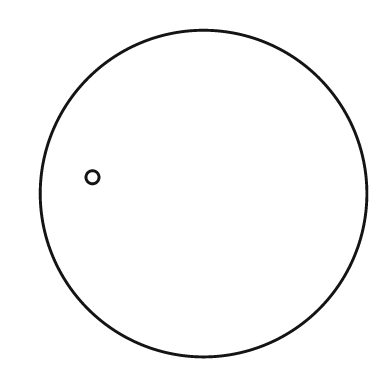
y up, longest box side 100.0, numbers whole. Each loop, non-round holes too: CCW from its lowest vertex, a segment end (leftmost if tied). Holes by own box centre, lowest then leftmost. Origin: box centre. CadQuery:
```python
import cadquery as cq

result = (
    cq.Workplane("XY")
    .moveTo(0.0, 0.0)
    .circle(50.0)
    .moveTo(-34.0, 5.0)
    .circle(2.0)
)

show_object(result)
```